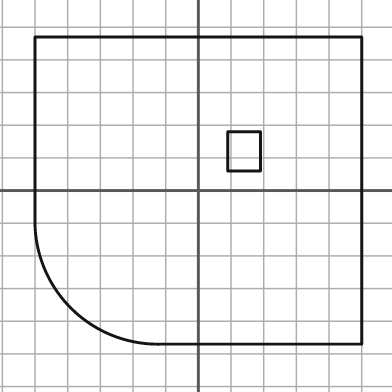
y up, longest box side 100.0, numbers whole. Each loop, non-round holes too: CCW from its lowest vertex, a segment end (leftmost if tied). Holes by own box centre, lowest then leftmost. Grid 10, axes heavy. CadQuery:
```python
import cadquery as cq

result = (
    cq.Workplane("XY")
    .moveTo(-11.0, -47.0)
    .lineTo(50.0, -47.0)
    .lineTo(50.0, 47.0)
    .lineTo(-50.0, 47.0)
    .lineTo(-50.0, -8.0)
    .threePointArc((-39.0, -36.0), (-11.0, -47.0))
    .close()
    .moveTo(9.0, 6.0)
    .lineTo(19.0, 6.0)
    .lineTo(19.0, 18.0)
    .lineTo(9.0, 18.0)
    .close()
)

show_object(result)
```